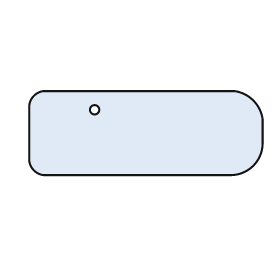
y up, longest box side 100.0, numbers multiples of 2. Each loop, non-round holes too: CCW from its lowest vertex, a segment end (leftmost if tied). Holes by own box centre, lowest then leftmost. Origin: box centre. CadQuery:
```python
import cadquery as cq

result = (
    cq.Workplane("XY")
    .moveTo(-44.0, -18.0)
    .lineTo(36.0, -18.0)
    .threePointArc((46.0, -14.0), (50.0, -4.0))
    .lineTo(50.0, 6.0)
    .threePointArc((46.0, 14.0), (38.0, 18.0))
    .lineTo(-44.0, 18.0)
    .threePointArc((-48.0, 16.0), (-50.0, 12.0))
    .lineTo(-50.0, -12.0)
    .threePointArc((-48.0, -16.0), (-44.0, -18.0))
    .close()
    .moveTo(-22.0, 10.0)
    .circle(2.0)
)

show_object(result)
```